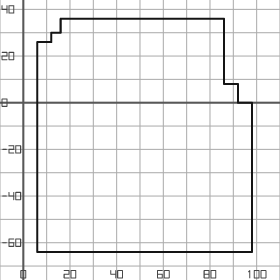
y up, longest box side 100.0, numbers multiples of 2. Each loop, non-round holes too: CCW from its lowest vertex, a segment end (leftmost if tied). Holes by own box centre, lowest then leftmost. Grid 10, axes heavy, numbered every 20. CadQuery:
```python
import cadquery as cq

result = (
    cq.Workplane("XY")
    .moveTo(6.0, -64.0)
    .lineTo(98.0, -64.0)
    .lineTo(98.0, 0.0)
    .lineTo(92.0, 0.0)
    .lineTo(92.0, 8.0)
    .lineTo(86.0, 8.0)
    .lineTo(86.0, 36.0)
    .lineTo(16.0, 36.0)
    .lineTo(16.0, 30.0)
    .lineTo(12.0, 30.0)
    .lineTo(12.0, 26.0)
    .lineTo(6.0, 26.0)
    .close()
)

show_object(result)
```